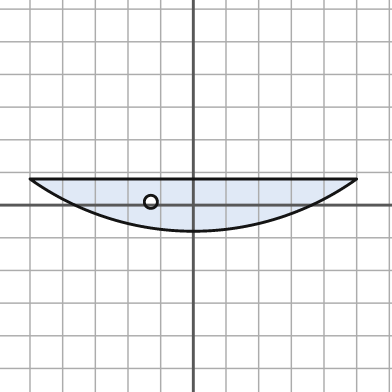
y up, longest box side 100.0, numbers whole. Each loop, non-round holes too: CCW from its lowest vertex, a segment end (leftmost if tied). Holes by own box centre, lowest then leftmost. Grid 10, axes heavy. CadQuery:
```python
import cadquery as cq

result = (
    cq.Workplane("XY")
    .moveTo(-50.0, 8.0)
    .threePointArc((0.0, -8.0), (50.0, 8.0))
    .close()
    .moveTo(-13.0, 1.0)
    .circle(2.0)
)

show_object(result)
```